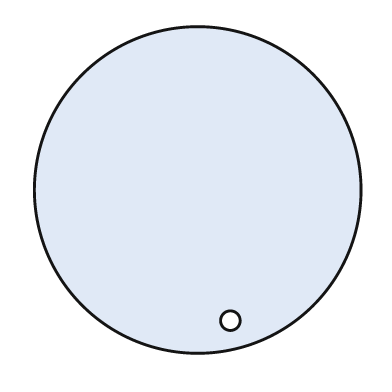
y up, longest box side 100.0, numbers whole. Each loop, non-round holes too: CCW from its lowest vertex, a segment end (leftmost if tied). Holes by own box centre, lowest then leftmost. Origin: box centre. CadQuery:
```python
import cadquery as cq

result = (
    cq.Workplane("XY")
    .moveTo(0.0, 0.0)
    .circle(50.0)
    .moveTo(10.0, -40.0)
    .circle(3.0)
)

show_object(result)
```